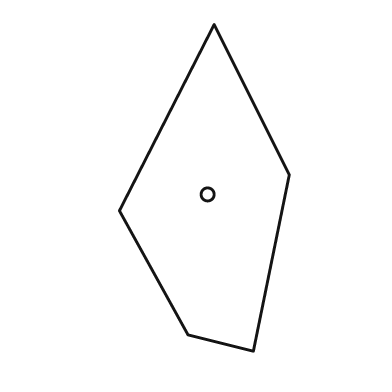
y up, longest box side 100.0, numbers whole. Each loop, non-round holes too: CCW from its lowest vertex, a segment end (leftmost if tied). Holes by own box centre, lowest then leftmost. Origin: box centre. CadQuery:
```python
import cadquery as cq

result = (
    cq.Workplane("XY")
    .moveTo(15.0, -50.0)
    .lineTo(26.0, 4.0)
    .lineTo(3.0, 50.0)
    .lineTo(-26.0, -7.0)
    .lineTo(-5.0, -45.0)
    .close()
    .moveTo(1.0, -2.0)
    .circle(2.0)
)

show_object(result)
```